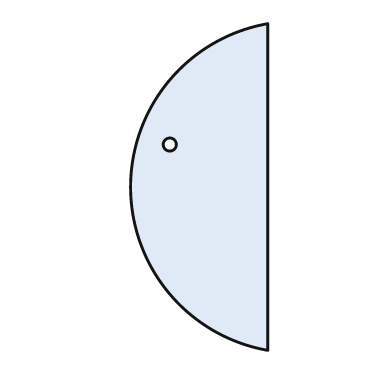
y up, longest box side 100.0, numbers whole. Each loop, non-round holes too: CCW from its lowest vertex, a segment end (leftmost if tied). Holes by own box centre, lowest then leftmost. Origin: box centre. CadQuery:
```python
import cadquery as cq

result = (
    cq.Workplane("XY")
    .moveTo(21.0, -50.0)
    .lineTo(21.0, 50.0)
    .threePointArc((-21.0, 0.0), (21.0, -50.0))
    .close()
    .moveTo(-9.0, 13.0)
    .circle(2.0)
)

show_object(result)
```